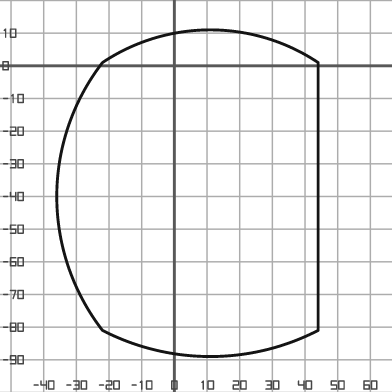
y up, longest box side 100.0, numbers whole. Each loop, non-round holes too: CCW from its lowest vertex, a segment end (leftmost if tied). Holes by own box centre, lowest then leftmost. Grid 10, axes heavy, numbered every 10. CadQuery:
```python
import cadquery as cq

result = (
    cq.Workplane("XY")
    .moveTo(-22.0, -81.0)
    .threePointArc((11.0, -89.0), (44.0, -81.0))
    .lineTo(44.0, 1.0)
    .threePointArc((11.0, 11.0), (-22.0, 1.0))
    .threePointArc((-36.0, -40.0), (-22.0, -81.0))
    .close()
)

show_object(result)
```